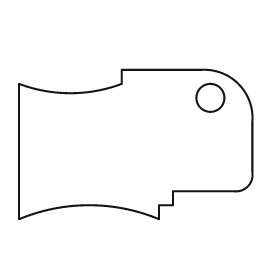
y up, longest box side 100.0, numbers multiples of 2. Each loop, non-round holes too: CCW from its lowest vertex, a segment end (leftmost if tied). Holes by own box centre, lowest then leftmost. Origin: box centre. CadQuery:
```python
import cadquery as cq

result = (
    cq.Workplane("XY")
    .moveTo(-50.0, -32.0)
    .threePointArc((-20.0, -26.0), (10.0, -32.0))
    .lineTo(10.0, -26.0)
    .lineTo(16.0, -26.0)
    .lineTo(16.0, -20.0)
    .lineTo(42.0, -20.0)
    .threePointArc((48.0, -18.0), (50.0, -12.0))
    .lineTo(50.0, 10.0)
    .threePointArc((44.0, 26.0), (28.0, 32.0))
    .lineTo(-6.0, 32.0)
    .lineTo(-6.0, 26.0)
    .threePointArc((-28.0, 22.0), (-50.0, 26.0))
    .close()
    .moveTo(32.0, 20.0)
    .circle(6.0)
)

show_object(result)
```